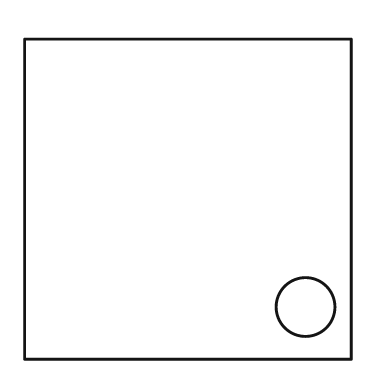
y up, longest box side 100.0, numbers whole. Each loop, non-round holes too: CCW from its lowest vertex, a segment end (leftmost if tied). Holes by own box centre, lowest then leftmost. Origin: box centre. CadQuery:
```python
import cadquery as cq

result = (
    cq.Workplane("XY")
    .moveTo(-50.0, -49.0)
    .lineTo(50.0, -49.0)
    .lineTo(50.0, 49.0)
    .lineTo(-50.0, 49.0)
    .close()
    .moveTo(36.0, -33.0)
    .circle(9.0)
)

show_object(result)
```